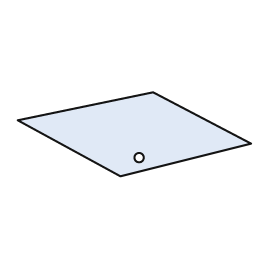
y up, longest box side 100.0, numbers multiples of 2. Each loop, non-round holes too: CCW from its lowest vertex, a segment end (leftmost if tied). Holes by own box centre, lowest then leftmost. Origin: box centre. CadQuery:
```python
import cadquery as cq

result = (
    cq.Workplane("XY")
    .moveTo(-6.0, -18.0)
    .lineTo(50.0, -4.0)
    .lineTo(8.0, 18.0)
    .lineTo(-50.0, 6.0)
    .close()
    .moveTo(2.0, -10.0)
    .circle(2.0)
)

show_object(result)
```